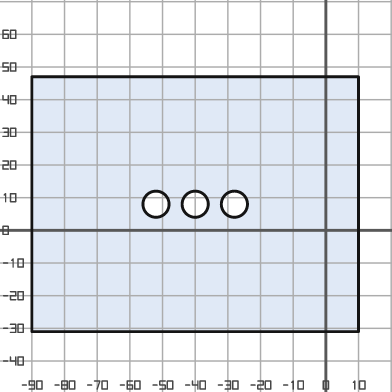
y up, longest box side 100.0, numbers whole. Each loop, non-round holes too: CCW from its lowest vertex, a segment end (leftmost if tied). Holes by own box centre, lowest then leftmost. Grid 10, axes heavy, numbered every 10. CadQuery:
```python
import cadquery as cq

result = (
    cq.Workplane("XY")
    .moveTo(-90.0, -31.0)
    .lineTo(10.0, -31.0)
    .lineTo(10.0, 47.0)
    .lineTo(-90.0, 47.0)
    .close()
    .moveTo(-52.0, 8.0)
    .circle(4.0)
    .moveTo(-40.0, 8.0)
    .circle(4.0)
    .moveTo(-28.0, 8.0)
    .circle(4.0)
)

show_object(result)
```